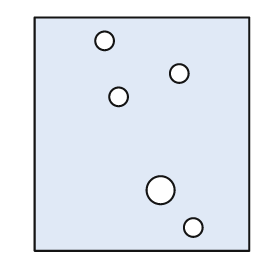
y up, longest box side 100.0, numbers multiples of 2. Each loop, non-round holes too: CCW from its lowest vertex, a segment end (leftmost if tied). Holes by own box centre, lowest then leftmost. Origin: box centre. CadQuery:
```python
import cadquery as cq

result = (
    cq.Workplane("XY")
    .moveTo(-46.0, -50.0)
    .lineTo(46.0, -50.0)
    .lineTo(46.0, 50.0)
    .lineTo(-46.0, 50.0)
    .close()
    .moveTo(22.0, -40.0)
    .circle(4.0)
    .moveTo(8.0, -24.0)
    .circle(6.0)
    .moveTo(-10.0, 16.0)
    .circle(4.0)
    .moveTo(16.0, 26.0)
    .circle(4.0)
    .moveTo(-16.0, 40.0)
    .circle(4.0)
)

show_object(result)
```